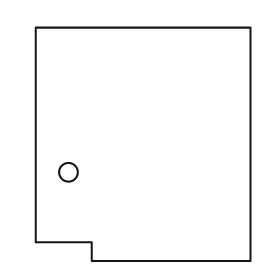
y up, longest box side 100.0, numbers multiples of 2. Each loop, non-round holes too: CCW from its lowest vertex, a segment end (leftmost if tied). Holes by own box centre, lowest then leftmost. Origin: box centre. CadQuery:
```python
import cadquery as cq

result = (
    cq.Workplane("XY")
    .moveTo(-22.0, -50.0)
    .lineTo(46.0, -50.0)
    .lineTo(46.0, 50.0)
    .lineTo(-46.0, 50.0)
    .lineTo(-46.0, -42.0)
    .lineTo(-22.0, -42.0)
    .close()
    .moveTo(-32.0, -12.0)
    .circle(4.0)
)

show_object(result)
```